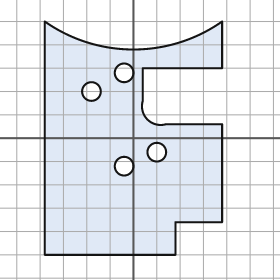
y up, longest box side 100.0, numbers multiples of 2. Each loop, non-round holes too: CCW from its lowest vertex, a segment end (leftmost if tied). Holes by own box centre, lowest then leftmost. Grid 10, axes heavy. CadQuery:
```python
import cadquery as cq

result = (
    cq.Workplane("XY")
    .moveTo(-38.0, -50.0)
    .lineTo(18.0, -50.0)
    .lineTo(18.0, -36.0)
    .lineTo(38.0, -36.0)
    .lineTo(38.0, 6.0)
    .lineTo(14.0, 6.0)
    .threePointArc((6.0, 8.0), (4.0, 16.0))
    .lineTo(4.0, 30.0)
    .lineTo(38.0, 30.0)
    .lineTo(38.0, 50.0)
    .threePointArc((0.0, 38.0), (-38.0, 50.0))
    .close()
    .moveTo(-4.0, -12.0)
    .circle(4.0)
    .moveTo(10.0, -6.0)
    .circle(4.0)
    .moveTo(-18.0, 20.0)
    .circle(4.0)
    .moveTo(-4.0, 28.0)
    .circle(4.0)
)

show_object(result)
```